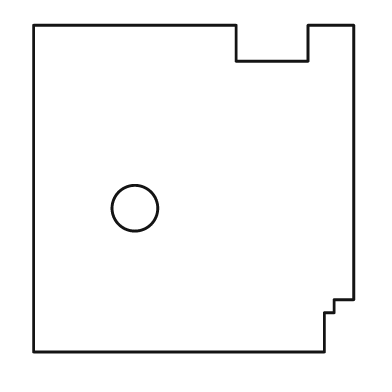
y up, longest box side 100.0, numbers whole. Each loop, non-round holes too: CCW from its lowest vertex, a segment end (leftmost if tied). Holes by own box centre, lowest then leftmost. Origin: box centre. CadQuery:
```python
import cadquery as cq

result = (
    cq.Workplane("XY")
    .moveTo(-49.0, -50.0)
    .lineTo(40.0, -50.0)
    .lineTo(40.0, -38.0)
    .lineTo(43.0, -38.0)
    .lineTo(43.0, -34.0)
    .lineTo(49.0, -34.0)
    .lineTo(49.0, 50.0)
    .lineTo(35.0, 50.0)
    .lineTo(35.0, 39.0)
    .lineTo(13.0, 39.0)
    .lineTo(13.0, 50.0)
    .lineTo(-49.0, 50.0)
    .close()
    .moveTo(-18.0, -6.0)
    .circle(7.0)
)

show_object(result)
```